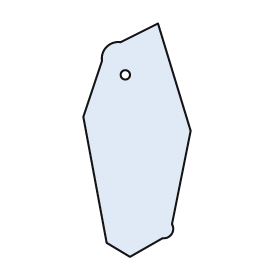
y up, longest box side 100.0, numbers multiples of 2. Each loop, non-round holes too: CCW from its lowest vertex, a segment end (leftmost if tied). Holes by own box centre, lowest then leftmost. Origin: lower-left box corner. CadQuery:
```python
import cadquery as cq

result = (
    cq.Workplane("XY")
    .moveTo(20.0, 0.0)
    .lineTo(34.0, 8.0)
    .threePointArc((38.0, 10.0), (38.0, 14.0))
    .lineTo(46.0, 54.0)
    .lineTo(32.0, 100.0)
    .lineTo(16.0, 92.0)
    .threePointArc((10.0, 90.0), (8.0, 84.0))
    .lineTo(0.0, 60.0)
    .lineTo(10.0, 6.0)
    .close()
    .moveTo(18.0, 78.0)
    .circle(2.0)
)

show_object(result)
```